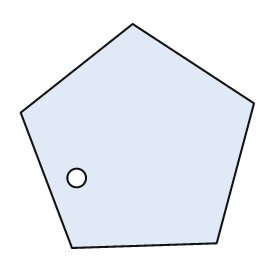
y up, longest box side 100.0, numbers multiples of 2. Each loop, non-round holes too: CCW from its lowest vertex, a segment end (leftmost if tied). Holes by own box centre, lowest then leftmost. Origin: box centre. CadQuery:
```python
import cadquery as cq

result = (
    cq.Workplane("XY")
    .moveTo(-28.0, -48.0)
    .lineTo(34.0, -46.0)
    .lineTo(50.0, 14.0)
    .lineTo(-2.0, 48.0)
    .lineTo(-50.0, 10.0)
    .close()
    .moveTo(-26.0, -18.0)
    .circle(4.0)
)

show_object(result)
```